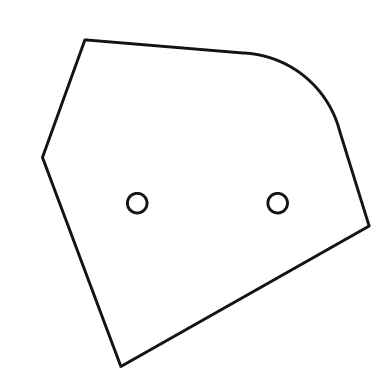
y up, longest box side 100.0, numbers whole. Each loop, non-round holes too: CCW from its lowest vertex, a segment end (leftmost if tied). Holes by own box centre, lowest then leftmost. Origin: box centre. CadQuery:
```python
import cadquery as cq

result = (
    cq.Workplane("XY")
    .moveTo(-26.0, -50.0)
    .lineTo(50.0, -7.0)
    .lineTo(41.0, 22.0)
    .threePointArc((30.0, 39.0), (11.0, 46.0))
    .lineTo(-37.0, 50.0)
    .lineTo(-50.0, 14.0)
    .close()
    .moveTo(-21.0, 0.0)
    .circle(3.0)
    .moveTo(22.0, 0.0)
    .circle(3.0)
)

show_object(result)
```